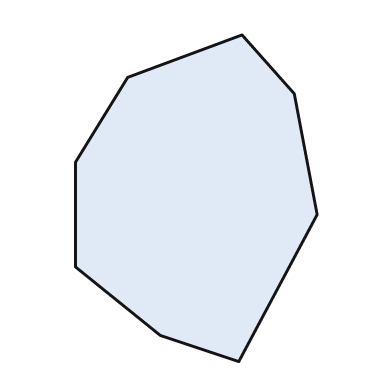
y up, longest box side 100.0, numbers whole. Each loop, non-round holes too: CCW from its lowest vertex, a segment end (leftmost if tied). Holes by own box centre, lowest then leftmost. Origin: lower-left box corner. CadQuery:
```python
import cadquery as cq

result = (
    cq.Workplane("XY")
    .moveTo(50.0, 0.0)
    .lineTo(74.0, 45.0)
    .lineTo(67.0, 82.0)
    .lineTo(51.0, 100.0)
    .lineTo(16.0, 87.0)
    .lineTo(0.0, 61.0)
    .lineTo(0.0, 29.0)
    .lineTo(26.0, 8.0)
    .close()
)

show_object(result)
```